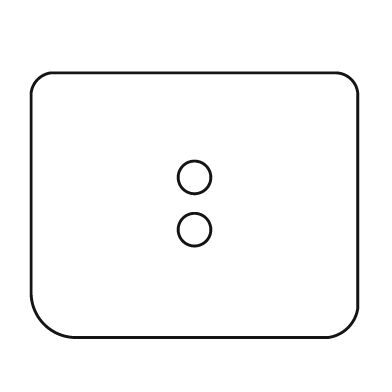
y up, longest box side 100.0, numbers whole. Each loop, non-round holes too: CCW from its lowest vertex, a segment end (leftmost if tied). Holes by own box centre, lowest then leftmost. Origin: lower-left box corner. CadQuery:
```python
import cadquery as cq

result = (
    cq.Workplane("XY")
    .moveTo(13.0, 0.0)
    .lineTo(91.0, 0.0)
    .threePointArc((97.0, 3.0), (100.0, 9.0))
    .lineTo(100.0, 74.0)
    .threePointArc((98.0, 79.0), (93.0, 81.0))
    .lineTo(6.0, 81.0)
    .threePointArc((2.0, 79.0), (0.0, 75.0))
    .lineTo(0.0, 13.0)
    .threePointArc((4.0, 4.0), (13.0, 0.0))
    .close()
    .moveTo(50.0, 33.0)
    .circle(5.0)
    .moveTo(50.0, 49.0)
    .circle(5.0)
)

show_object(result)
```